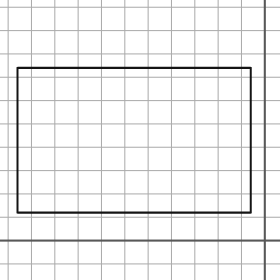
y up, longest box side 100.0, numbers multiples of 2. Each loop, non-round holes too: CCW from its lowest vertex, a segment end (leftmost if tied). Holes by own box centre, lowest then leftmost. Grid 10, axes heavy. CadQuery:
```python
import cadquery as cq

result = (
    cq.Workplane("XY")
    .moveTo(-106.0, 12.0)
    .lineTo(-6.0, 12.0)
    .lineTo(-6.0, 74.0)
    .lineTo(-106.0, 74.0)
    .close()
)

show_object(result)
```